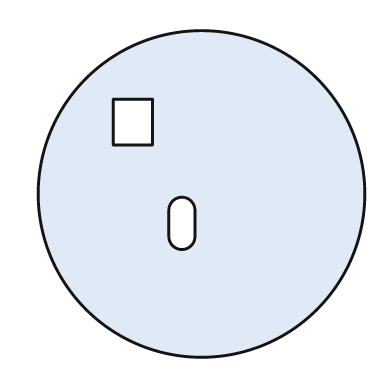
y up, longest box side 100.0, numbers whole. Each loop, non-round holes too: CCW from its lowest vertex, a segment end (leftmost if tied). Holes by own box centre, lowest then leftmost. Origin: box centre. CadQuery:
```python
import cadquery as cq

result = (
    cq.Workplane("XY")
    .moveTo(0.0, 0.0)
    .circle(50.0)
    .moveTo(-10.0, -13.0)
    .threePointArc((-6.0, -17.0), (-2.0, -13.0))
    .lineTo(-2.0, -5.0)
    .threePointArc((-6.0, -1.0), (-10.0, -5.0))
    .close()
    .moveTo(-27.0, 15.0)
    .lineTo(-15.0, 15.0)
    .lineTo(-15.0, 29.0)
    .lineTo(-27.0, 29.0)
    .close()
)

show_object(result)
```